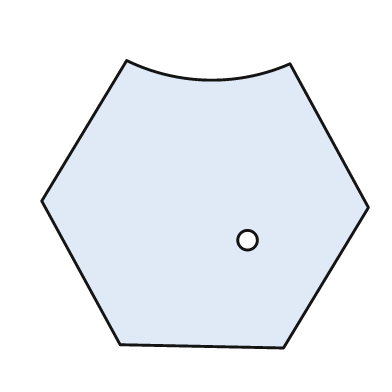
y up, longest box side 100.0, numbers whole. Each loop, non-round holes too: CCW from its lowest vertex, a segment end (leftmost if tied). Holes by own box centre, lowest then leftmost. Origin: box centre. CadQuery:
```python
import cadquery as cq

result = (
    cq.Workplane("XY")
    .moveTo(24.0, -44.0)
    .lineTo(50.0, -1.0)
    .lineTo(26.0, 43.0)
    .threePointArc((1.0, 38.0), (-24.0, 44.0))
    .lineTo(-50.0, 1.0)
    .lineTo(-26.0, -43.0)
    .close()
    .moveTo(13.0, -11.0)
    .circle(3.0)
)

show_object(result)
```